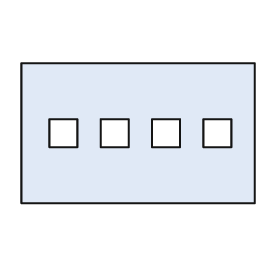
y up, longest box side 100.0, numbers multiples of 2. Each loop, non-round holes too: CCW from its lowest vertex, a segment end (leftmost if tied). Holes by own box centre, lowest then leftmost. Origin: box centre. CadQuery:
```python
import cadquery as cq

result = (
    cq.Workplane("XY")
    .moveTo(-50.0, -30.0)
    .lineTo(50.0, -30.0)
    .lineTo(50.0, 30.0)
    .lineTo(-50.0, 30.0)
    .close()
    .moveTo(-38.0, -6.0)
    .lineTo(-26.0, -6.0)
    .lineTo(-26.0, 6.0)
    .lineTo(-38.0, 6.0)
    .close()
    .moveTo(-16.0, -6.0)
    .lineTo(-4.0, -6.0)
    .lineTo(-4.0, 6.0)
    .lineTo(-16.0, 6.0)
    .close()
    .moveTo(6.0, -6.0)
    .lineTo(18.0, -6.0)
    .lineTo(18.0, 6.0)
    .lineTo(6.0, 6.0)
    .close()
    .moveTo(28.0, -6.0)
    .lineTo(40.0, -6.0)
    .lineTo(40.0, 6.0)
    .lineTo(28.0, 6.0)
    .close()
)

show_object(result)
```